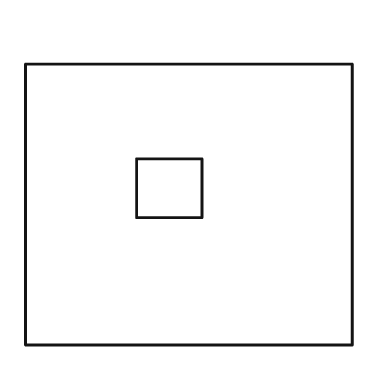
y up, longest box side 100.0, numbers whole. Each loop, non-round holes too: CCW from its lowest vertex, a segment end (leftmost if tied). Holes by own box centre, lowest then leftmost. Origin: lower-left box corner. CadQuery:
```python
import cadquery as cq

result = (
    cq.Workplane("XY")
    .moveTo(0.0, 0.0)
    .lineTo(100.0, 0.0)
    .lineTo(100.0, 86.0)
    .lineTo(0.0, 86.0)
    .close()
    .moveTo(34.0, 39.0)
    .lineTo(54.0, 39.0)
    .lineTo(54.0, 57.0)
    .lineTo(34.0, 57.0)
    .close()
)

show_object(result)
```